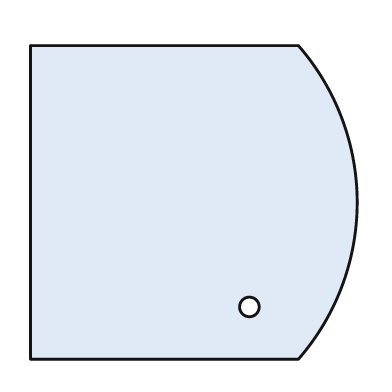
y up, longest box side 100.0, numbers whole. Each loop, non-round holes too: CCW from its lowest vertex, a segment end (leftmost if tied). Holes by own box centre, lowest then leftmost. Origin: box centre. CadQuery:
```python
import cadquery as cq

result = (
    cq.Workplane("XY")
    .moveTo(-50.0, -48.0)
    .lineTo(32.0, -48.0)
    .threePointArc((50.0, 0.0), (32.0, 48.0))
    .lineTo(-50.0, 48.0)
    .close()
    .moveTo(17.0, -32.0)
    .circle(3.0)
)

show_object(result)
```